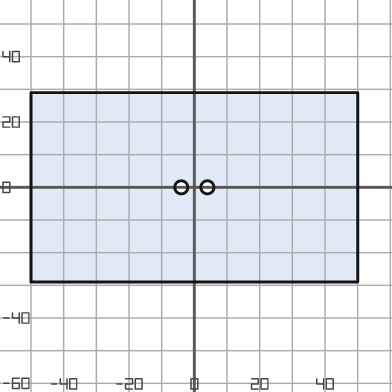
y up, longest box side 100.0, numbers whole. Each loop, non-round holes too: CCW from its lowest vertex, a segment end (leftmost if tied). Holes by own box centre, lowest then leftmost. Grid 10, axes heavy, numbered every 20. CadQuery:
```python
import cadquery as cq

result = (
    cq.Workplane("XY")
    .moveTo(-50.0, -29.0)
    .lineTo(50.0, -29.0)
    .lineTo(50.0, 29.0)
    .lineTo(-50.0, 29.0)
    .close()
    .moveTo(-4.0, 0.0)
    .circle(2.0)
    .moveTo(4.0, 0.0)
    .circle(2.0)
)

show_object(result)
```